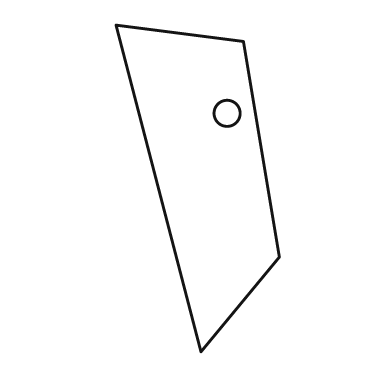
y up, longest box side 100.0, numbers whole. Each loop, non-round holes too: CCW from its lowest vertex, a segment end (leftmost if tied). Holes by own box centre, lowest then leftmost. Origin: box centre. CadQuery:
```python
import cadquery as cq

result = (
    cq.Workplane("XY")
    .moveTo(1.0, -50.0)
    .lineTo(25.0, -21.0)
    .lineTo(14.0, 45.0)
    .lineTo(-25.0, 50.0)
    .close()
    .moveTo(9.0, 23.0)
    .circle(4.0)
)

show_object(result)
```